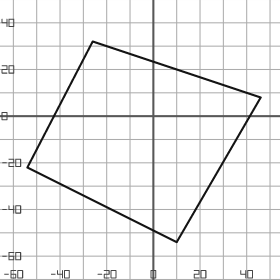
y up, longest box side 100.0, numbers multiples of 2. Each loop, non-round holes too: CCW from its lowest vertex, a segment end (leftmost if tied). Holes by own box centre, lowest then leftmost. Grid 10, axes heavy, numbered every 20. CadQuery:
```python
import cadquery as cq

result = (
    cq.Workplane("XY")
    .moveTo(10.0, -54.0)
    .lineTo(46.0, 8.0)
    .lineTo(-26.0, 32.0)
    .lineTo(-54.0, -22.0)
    .close()
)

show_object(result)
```